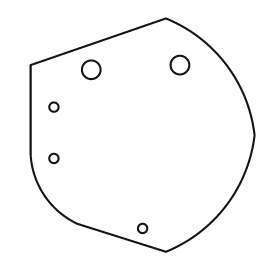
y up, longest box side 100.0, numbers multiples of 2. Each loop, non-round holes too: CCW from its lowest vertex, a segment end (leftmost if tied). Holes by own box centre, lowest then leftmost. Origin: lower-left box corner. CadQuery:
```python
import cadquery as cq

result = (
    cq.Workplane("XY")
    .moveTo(58.0, 0.0)
    .threePointArc((84.0, 20.0), (96.0, 50.0))
    .threePointArc((84.0, 80.0), (58.0, 100.0))
    .lineTo(0.0, 80.0)
    .lineTo(0.0, 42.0)
    .threePointArc((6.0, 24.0), (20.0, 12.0))
    .close()
    .moveTo(48.0, 10.0)
    .circle(2.0)
    .moveTo(10.0, 40.0)
    .circle(2.0)
    .moveTo(10.0, 62.0)
    .circle(2.0)
    .moveTo(26.0, 78.0)
    .circle(4.0)
    .moveTo(64.0, 80.0)
    .circle(4.0)
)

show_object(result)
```